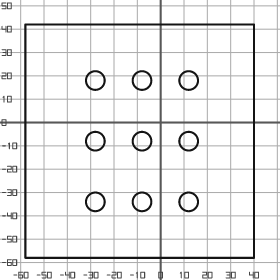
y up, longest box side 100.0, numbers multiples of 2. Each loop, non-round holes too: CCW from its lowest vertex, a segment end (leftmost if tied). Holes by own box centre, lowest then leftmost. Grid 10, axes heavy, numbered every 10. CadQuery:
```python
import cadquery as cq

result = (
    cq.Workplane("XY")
    .moveTo(-58.0, -58.0)
    .lineTo(40.0, -58.0)
    .lineTo(40.0, 42.0)
    .lineTo(-58.0, 42.0)
    .close()
    .moveTo(-28.0, -34.0)
    .circle(4.0)
    .moveTo(-8.0, -34.0)
    .circle(4.0)
    .moveTo(12.0, -34.0)
    .circle(4.0)
    .moveTo(-28.0, -8.0)
    .circle(4.0)
    .moveTo(-8.0, -8.0)
    .circle(4.0)
    .moveTo(12.0, -8.0)
    .circle(4.0)
    .moveTo(-28.0, 18.0)
    .circle(4.0)
    .moveTo(-8.0, 18.0)
    .circle(4.0)
    .moveTo(12.0, 18.0)
    .circle(4.0)
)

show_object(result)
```